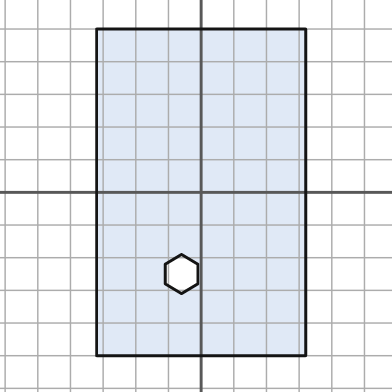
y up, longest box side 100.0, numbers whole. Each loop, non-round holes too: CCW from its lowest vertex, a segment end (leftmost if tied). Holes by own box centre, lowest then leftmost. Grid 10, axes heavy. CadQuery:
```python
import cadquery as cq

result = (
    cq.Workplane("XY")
    .moveTo(-32.0, -50.0)
    .lineTo(32.0, -50.0)
    .lineTo(32.0, 50.0)
    .lineTo(-32.0, 50.0)
    .close()
    .moveTo(-6.0, -31.0)
    .lineTo(-1.0, -28.0)
    .lineTo(-1.0, -22.0)
    .lineTo(-6.0, -19.0)
    .lineTo(-11.0, -22.0)
    .lineTo(-11.0, -28.0)
    .close()
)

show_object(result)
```